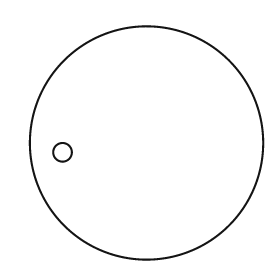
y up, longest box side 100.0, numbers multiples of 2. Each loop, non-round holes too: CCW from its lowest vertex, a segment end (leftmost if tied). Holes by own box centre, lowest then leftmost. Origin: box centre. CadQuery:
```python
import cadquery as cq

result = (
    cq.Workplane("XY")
    .moveTo(0.0, 0.0)
    .circle(50.0)
    .moveTo(-36.0, -4.0)
    .circle(4.0)
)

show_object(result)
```